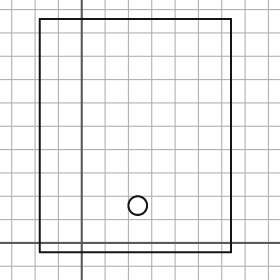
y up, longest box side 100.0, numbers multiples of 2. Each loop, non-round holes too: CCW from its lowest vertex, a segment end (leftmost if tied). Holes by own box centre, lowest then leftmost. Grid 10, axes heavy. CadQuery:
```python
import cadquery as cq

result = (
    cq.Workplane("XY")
    .moveTo(-18.0, -4.0)
    .lineTo(64.0, -4.0)
    .lineTo(64.0, 96.0)
    .lineTo(-18.0, 96.0)
    .close()
    .moveTo(24.0, 16.0)
    .circle(4.0)
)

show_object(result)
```